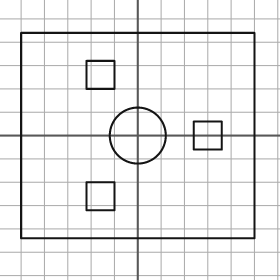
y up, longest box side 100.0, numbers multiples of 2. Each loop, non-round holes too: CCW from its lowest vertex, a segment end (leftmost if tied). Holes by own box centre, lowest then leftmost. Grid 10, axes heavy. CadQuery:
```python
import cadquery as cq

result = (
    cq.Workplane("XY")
    .moveTo(-50.0, -44.0)
    .lineTo(50.0, -44.0)
    .lineTo(50.0, 44.0)
    .lineTo(-50.0, 44.0)
    .close()
    .moveTo(-22.0, -32.0)
    .lineTo(-10.0, -32.0)
    .lineTo(-10.0, -20.0)
    .lineTo(-22.0, -20.0)
    .close()
    .moveTo(0.0, 0.0)
    .circle(12.0)
    .moveTo(24.0, -6.0)
    .lineTo(36.0, -6.0)
    .lineTo(36.0, 6.0)
    .lineTo(24.0, 6.0)
    .close()
    .moveTo(-22.0, 20.0)
    .lineTo(-10.0, 20.0)
    .lineTo(-10.0, 32.0)
    .lineTo(-22.0, 32.0)
    .close()
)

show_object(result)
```